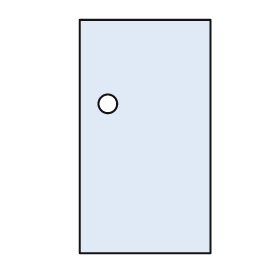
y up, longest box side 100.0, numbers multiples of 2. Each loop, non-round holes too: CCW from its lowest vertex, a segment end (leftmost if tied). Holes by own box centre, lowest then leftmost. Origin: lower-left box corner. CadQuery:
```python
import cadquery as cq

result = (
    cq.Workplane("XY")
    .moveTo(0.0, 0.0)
    .lineTo(56.0, 0.0)
    .lineTo(56.0, 100.0)
    .lineTo(0.0, 100.0)
    .close()
    .moveTo(12.0, 64.0)
    .circle(4.0)
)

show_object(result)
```